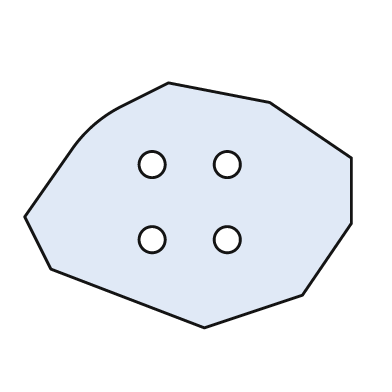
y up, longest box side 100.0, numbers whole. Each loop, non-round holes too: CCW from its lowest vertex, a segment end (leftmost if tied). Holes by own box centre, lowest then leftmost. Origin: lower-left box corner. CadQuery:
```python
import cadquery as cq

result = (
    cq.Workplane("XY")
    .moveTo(55.0, 0.0)
    .lineTo(85.0, 10.0)
    .lineTo(100.0, 32.0)
    .lineTo(100.0, 52.0)
    .lineTo(75.0, 69.0)
    .lineTo(44.0, 75.0)
    .lineTo(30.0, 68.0)
    .threePointArc((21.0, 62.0), (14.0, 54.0))
    .lineTo(0.0, 34.0)
    .lineTo(8.0, 18.0)
    .close()
    .moveTo(39.0, 27.0)
    .circle(4.0)
    .moveTo(62.0, 27.0)
    .circle(4.0)
    .moveTo(39.0, 50.0)
    .circle(4.0)
    .moveTo(62.0, 50.0)
    .circle(4.0)
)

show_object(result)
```